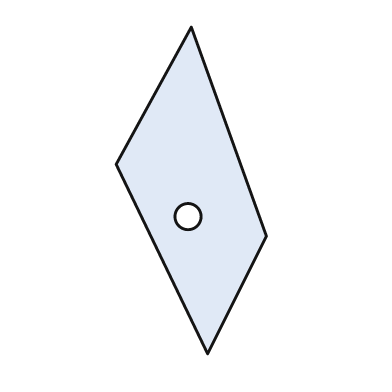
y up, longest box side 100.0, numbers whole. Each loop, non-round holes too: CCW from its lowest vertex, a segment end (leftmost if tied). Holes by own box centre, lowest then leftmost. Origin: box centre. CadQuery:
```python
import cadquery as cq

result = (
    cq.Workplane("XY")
    .moveTo(5.0, -50.0)
    .lineTo(23.0, -14.0)
    .lineTo(0.0, 50.0)
    .lineTo(-23.0, 8.0)
    .close()
    .moveTo(-1.0, -8.0)
    .circle(4.0)
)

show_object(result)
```